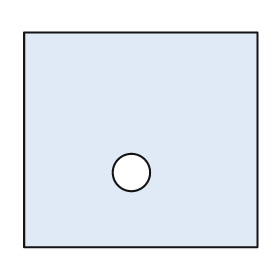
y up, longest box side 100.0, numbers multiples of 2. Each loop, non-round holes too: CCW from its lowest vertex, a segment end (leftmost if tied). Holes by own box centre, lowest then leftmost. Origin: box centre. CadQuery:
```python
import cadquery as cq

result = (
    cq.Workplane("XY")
    .moveTo(-50.0, -46.0)
    .lineTo(50.0, -46.0)
    .lineTo(50.0, 46.0)
    .lineTo(-50.0, 46.0)
    .close()
    .moveTo(-4.0, -14.0)
    .circle(8.0)
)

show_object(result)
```